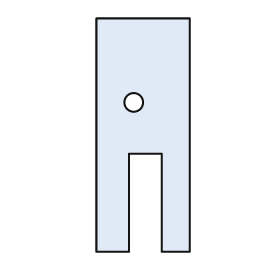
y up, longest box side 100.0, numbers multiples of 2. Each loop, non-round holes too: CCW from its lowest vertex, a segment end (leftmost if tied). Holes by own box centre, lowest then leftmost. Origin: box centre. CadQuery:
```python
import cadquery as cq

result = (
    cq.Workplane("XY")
    .moveTo(-20.0, -50.0)
    .lineTo(-6.0, -50.0)
    .lineTo(-6.0, -8.0)
    .lineTo(8.0, -8.0)
    .lineTo(8.0, -50.0)
    .lineTo(20.0, -50.0)
    .lineTo(20.0, 50.0)
    .lineTo(-20.0, 50.0)
    .close()
    .moveTo(-4.0, 14.0)
    .circle(4.0)
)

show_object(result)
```